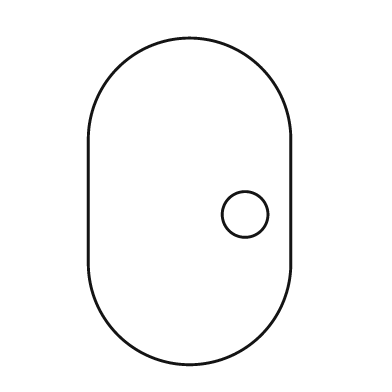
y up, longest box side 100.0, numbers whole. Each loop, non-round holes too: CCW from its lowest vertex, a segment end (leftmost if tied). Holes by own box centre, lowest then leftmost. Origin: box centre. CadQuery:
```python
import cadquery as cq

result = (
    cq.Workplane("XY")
    .moveTo(-31.0, -19.0)
    .threePointArc((0.0, -50.0), (31.0, -19.0))
    .lineTo(31.0, 19.0)
    .threePointArc((0.0, 50.0), (-31.0, 19.0))
    .close()
    .moveTo(17.0, -4.0)
    .circle(7.0)
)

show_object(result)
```